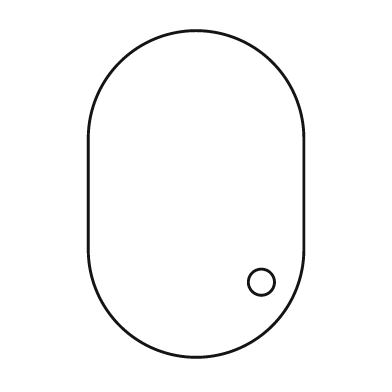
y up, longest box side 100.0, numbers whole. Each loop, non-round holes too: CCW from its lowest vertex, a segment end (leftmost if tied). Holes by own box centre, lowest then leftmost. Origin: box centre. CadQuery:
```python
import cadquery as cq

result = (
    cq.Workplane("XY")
    .moveTo(-33.0, -17.0)
    .threePointArc((0.0, -50.0), (33.0, -17.0))
    .lineTo(33.0, 17.0)
    .threePointArc((0.0, 50.0), (-33.0, 17.0))
    .close()
    .moveTo(20.0, -27.0)
    .circle(4.0)
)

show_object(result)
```